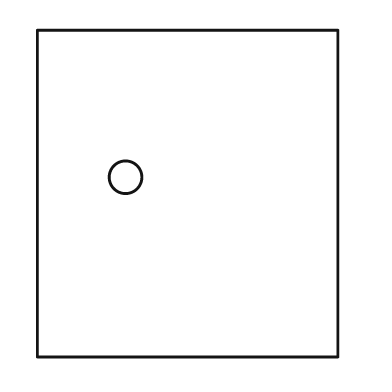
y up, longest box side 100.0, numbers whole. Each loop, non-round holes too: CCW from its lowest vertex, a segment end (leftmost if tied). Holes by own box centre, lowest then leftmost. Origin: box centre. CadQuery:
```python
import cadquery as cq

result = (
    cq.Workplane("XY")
    .moveTo(-46.0, -50.0)
    .lineTo(46.0, -50.0)
    .lineTo(46.0, 50.0)
    .lineTo(-46.0, 50.0)
    .close()
    .moveTo(-19.0, 5.0)
    .circle(5.0)
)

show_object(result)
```